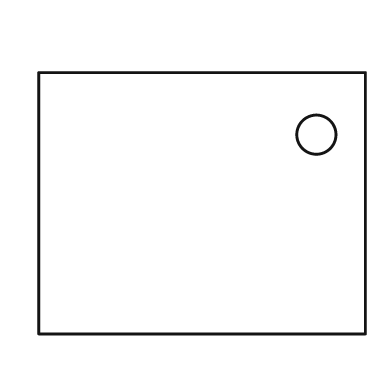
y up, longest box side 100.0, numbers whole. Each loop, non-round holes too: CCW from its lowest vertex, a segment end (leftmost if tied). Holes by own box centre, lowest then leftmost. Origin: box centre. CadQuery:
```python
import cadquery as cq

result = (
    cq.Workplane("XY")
    .moveTo(-50.0, -40.0)
    .lineTo(50.0, -40.0)
    .lineTo(50.0, 40.0)
    .lineTo(-50.0, 40.0)
    .close()
    .moveTo(35.0, 21.0)
    .circle(6.0)
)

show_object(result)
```